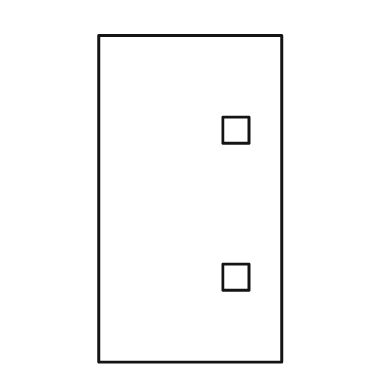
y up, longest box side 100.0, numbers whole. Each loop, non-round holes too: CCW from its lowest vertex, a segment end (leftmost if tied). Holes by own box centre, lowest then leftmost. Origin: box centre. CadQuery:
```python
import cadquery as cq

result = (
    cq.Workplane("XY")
    .moveTo(-28.0, -50.0)
    .lineTo(28.0, -50.0)
    .lineTo(28.0, 50.0)
    .lineTo(-28.0, 50.0)
    .close()
    .moveTo(10.0, -28.0)
    .lineTo(18.0, -28.0)
    .lineTo(18.0, -20.0)
    .lineTo(10.0, -20.0)
    .close()
    .moveTo(10.0, 17.0)
    .lineTo(18.0, 17.0)
    .lineTo(18.0, 25.0)
    .lineTo(10.0, 25.0)
    .close()
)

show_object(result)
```